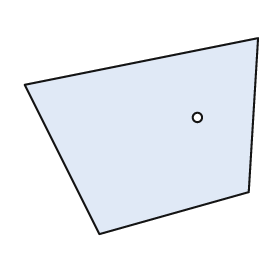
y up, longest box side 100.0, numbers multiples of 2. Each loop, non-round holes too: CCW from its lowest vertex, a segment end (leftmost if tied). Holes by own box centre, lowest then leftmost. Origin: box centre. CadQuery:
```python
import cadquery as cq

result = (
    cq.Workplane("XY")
    .moveTo(-18.0, -42.0)
    .lineTo(46.0, -24.0)
    .lineTo(50.0, 42.0)
    .lineTo(-50.0, 22.0)
    .close()
    .moveTo(24.0, 8.0)
    .circle(2.0)
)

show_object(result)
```